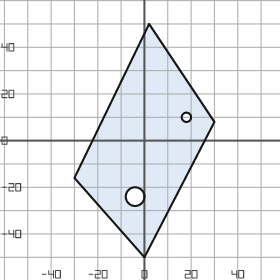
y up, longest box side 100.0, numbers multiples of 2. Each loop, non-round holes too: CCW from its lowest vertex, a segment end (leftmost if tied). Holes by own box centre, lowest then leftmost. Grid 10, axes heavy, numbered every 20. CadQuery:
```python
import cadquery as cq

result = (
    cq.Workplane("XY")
    .moveTo(0.0, -50.0)
    .lineTo(30.0, 8.0)
    .lineTo(2.0, 50.0)
    .lineTo(-30.0, -16.0)
    .close()
    .moveTo(-4.0, -24.0)
    .circle(4.0)
    .moveTo(18.0, 10.0)
    .circle(2.0)
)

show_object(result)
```